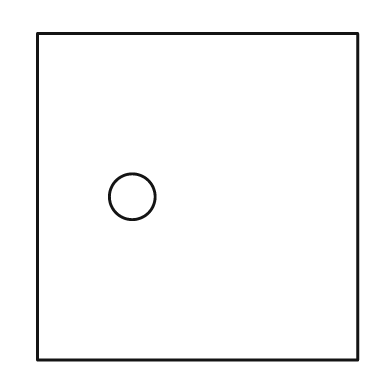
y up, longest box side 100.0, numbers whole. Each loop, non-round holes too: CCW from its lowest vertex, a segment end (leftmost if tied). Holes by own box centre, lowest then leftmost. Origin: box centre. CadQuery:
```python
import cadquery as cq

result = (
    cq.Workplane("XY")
    .moveTo(-49.0, -50.0)
    .lineTo(49.0, -50.0)
    .lineTo(49.0, 50.0)
    .lineTo(-49.0, 50.0)
    .close()
    .moveTo(-20.0, 0.0)
    .circle(7.0)
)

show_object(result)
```